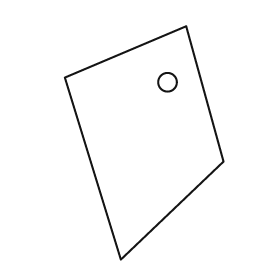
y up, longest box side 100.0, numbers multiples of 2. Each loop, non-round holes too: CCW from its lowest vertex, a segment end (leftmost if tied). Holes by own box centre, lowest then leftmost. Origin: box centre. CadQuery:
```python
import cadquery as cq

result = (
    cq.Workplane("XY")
    .moveTo(-10.0, -50.0)
    .lineTo(34.0, -8.0)
    .lineTo(18.0, 50.0)
    .lineTo(-34.0, 28.0)
    .close()
    .moveTo(10.0, 26.0)
    .circle(4.0)
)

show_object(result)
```